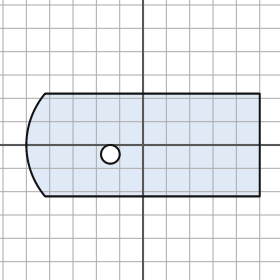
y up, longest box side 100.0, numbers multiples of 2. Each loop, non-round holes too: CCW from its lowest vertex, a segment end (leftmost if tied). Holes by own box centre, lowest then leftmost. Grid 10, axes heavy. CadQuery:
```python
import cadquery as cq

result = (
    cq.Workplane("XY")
    .moveTo(-42.0, -22.0)
    .lineTo(50.0, -22.0)
    .lineTo(50.0, 22.0)
    .lineTo(-42.0, 22.0)
    .threePointArc((-50.0, 0.0), (-42.0, -22.0))
    .close()
    .moveTo(-14.0, -4.0)
    .circle(4.0)
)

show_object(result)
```